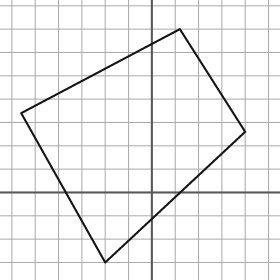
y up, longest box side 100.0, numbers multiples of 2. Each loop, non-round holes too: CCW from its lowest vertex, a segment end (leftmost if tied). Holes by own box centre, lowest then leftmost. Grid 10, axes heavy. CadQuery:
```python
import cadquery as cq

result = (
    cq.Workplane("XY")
    .moveTo(-20.0, -30.0)
    .lineTo(40.0, 26.0)
    .lineTo(12.0, 70.0)
    .lineTo(-56.0, 34.0)
    .close()
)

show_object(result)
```